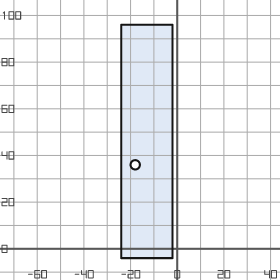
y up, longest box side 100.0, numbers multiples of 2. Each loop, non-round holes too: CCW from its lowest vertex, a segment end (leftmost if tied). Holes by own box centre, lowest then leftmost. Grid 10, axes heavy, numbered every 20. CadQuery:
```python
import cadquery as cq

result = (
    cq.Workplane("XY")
    .moveTo(-24.0, -4.0)
    .lineTo(-2.0, -4.0)
    .lineTo(-2.0, 96.0)
    .lineTo(-24.0, 96.0)
    .close()
    .moveTo(-18.0, 36.0)
    .circle(2.0)
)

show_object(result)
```